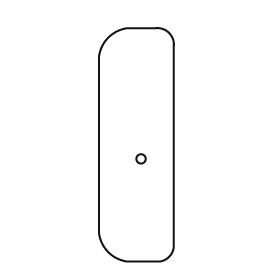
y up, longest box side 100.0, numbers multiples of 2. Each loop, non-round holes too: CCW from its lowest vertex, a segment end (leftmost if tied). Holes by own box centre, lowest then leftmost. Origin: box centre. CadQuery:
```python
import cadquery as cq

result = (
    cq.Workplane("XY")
    .moveTo(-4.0, -50.0)
    .lineTo(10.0, -50.0)
    .threePointArc((14.0, -48.0), (16.0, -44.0))
    .lineTo(16.0, 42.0)
    .threePointArc((14.0, 48.0), (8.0, 50.0))
    .lineTo(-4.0, 50.0)
    .threePointArc((-12.0, 46.0), (-16.0, 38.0))
    .lineTo(-16.0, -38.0)
    .threePointArc((-12.0, -46.0), (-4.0, -50.0))
    .close()
    .moveTo(2.0, -6.0)
    .circle(2.0)
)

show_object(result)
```